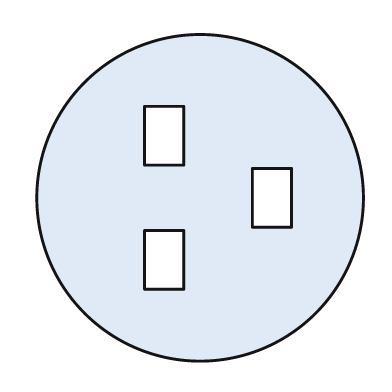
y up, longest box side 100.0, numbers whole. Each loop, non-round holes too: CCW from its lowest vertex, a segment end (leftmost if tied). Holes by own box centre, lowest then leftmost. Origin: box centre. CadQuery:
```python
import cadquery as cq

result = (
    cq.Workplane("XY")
    .moveTo(0.0, 0.0)
    .circle(50.0)
    .moveTo(-17.0, -28.0)
    .lineTo(-5.0, -28.0)
    .lineTo(-5.0, -10.0)
    .lineTo(-17.0, -10.0)
    .close()
    .moveTo(16.0, -9.0)
    .lineTo(28.0, -9.0)
    .lineTo(28.0, 9.0)
    .lineTo(16.0, 9.0)
    .close()
    .moveTo(-17.0, 10.0)
    .lineTo(-5.0, 10.0)
    .lineTo(-5.0, 28.0)
    .lineTo(-17.0, 28.0)
    .close()
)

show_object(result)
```